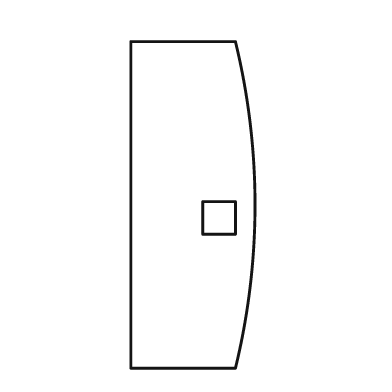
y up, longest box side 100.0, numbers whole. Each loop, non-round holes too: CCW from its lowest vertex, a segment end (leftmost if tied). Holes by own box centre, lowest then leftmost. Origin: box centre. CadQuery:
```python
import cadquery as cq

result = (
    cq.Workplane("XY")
    .moveTo(-19.0, -50.0)
    .lineTo(13.0, -50.0)
    .threePointArc((19.0, 0.0), (13.0, 50.0))
    .lineTo(-19.0, 50.0)
    .close()
    .moveTo(3.0, -9.0)
    .lineTo(13.0, -9.0)
    .lineTo(13.0, 1.0)
    .lineTo(3.0, 1.0)
    .close()
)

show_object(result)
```